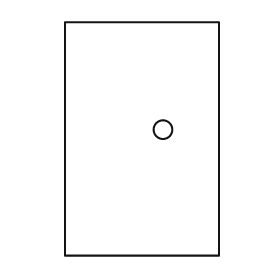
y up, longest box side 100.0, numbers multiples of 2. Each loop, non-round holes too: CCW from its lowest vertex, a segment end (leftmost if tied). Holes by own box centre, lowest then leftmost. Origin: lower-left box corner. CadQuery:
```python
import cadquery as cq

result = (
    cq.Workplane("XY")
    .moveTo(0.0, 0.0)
    .lineTo(66.0, 0.0)
    .lineTo(66.0, 100.0)
    .lineTo(0.0, 100.0)
    .close()
    .moveTo(42.0, 54.0)
    .circle(4.0)
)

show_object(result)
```